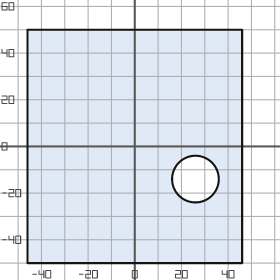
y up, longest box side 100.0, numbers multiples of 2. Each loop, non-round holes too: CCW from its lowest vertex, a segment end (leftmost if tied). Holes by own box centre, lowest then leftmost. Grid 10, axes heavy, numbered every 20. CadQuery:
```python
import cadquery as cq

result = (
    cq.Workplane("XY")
    .moveTo(-46.0, -50.0)
    .lineTo(46.0, -50.0)
    .lineTo(46.0, 50.0)
    .lineTo(-46.0, 50.0)
    .close()
    .moveTo(26.0, -14.0)
    .circle(10.0)
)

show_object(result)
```